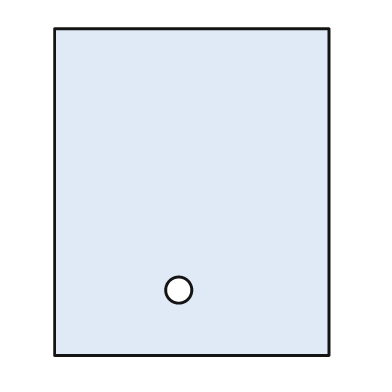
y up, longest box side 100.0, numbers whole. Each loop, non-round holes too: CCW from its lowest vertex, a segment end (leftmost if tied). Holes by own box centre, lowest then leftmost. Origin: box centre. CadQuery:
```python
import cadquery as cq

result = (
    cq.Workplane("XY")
    .moveTo(-42.0, -50.0)
    .lineTo(42.0, -50.0)
    .lineTo(42.0, 50.0)
    .lineTo(-42.0, 50.0)
    .close()
    .moveTo(-4.0, -30.0)
    .circle(4.0)
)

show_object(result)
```